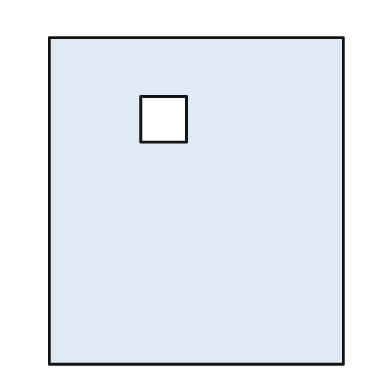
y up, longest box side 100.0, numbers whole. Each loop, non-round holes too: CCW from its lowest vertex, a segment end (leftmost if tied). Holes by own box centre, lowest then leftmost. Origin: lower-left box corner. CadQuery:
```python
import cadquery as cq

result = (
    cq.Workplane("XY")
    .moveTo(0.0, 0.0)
    .lineTo(90.0, 0.0)
    .lineTo(90.0, 100.0)
    .lineTo(0.0, 100.0)
    .close()
    .moveTo(28.0, 68.0)
    .lineTo(42.0, 68.0)
    .lineTo(42.0, 82.0)
    .lineTo(28.0, 82.0)
    .close()
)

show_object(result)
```